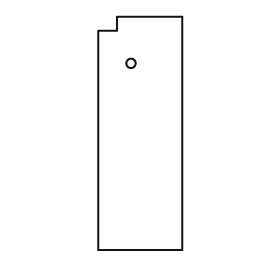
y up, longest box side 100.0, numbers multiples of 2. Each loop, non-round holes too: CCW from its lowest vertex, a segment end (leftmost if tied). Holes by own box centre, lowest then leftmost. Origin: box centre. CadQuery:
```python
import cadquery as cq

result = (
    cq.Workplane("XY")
    .moveTo(-18.0, -50.0)
    .lineTo(18.0, -50.0)
    .lineTo(18.0, 50.0)
    .lineTo(-10.0, 50.0)
    .lineTo(-10.0, 44.0)
    .lineTo(-18.0, 44.0)
    .close()
    .moveTo(-4.0, 30.0)
    .circle(2.0)
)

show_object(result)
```